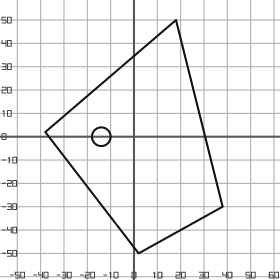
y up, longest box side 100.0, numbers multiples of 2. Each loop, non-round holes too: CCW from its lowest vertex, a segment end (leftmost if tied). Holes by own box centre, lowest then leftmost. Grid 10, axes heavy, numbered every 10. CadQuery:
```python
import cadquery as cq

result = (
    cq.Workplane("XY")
    .moveTo(2.0, -50.0)
    .lineTo(38.0, -30.0)
    .lineTo(18.0, 50.0)
    .lineTo(-38.0, 2.0)
    .close()
    .moveTo(-14.0, 0.0)
    .circle(4.0)
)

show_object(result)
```